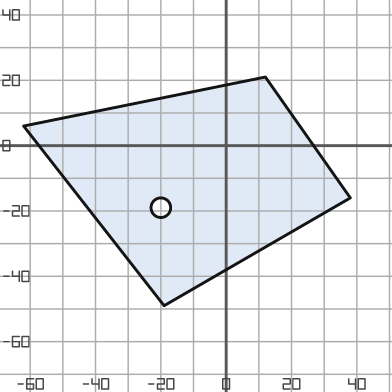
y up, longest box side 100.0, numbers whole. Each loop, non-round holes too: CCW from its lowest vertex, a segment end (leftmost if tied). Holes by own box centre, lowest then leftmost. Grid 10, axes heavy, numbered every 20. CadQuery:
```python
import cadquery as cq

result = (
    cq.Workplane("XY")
    .moveTo(-19.0, -49.0)
    .lineTo(38.0, -16.0)
    .lineTo(12.0, 21.0)
    .lineTo(-62.0, 6.0)
    .close()
    .moveTo(-20.0, -19.0)
    .circle(3.0)
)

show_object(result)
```